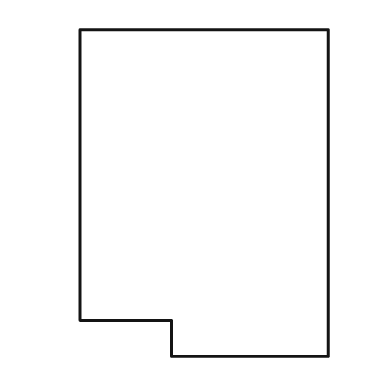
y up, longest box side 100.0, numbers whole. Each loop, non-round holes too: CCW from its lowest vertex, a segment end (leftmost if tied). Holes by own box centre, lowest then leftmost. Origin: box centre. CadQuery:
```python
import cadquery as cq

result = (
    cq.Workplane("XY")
    .moveTo(-10.0, -50.0)
    .lineTo(38.0, -50.0)
    .lineTo(38.0, 50.0)
    .lineTo(-38.0, 50.0)
    .lineTo(-38.0, -39.0)
    .lineTo(-10.0, -39.0)
    .close()
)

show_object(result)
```